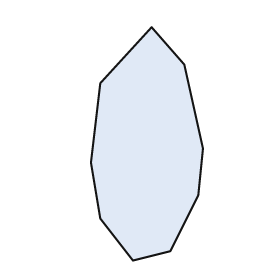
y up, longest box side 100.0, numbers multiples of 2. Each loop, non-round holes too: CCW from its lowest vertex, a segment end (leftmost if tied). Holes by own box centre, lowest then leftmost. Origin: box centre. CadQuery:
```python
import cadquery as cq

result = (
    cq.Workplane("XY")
    .moveTo(-6.0, -50.0)
    .lineTo(10.0, -46.0)
    .lineTo(22.0, -22.0)
    .lineTo(24.0, -2.0)
    .lineTo(16.0, 34.0)
    .lineTo(2.0, 50.0)
    .lineTo(-20.0, 26.0)
    .lineTo(-24.0, -8.0)
    .lineTo(-20.0, -32.0)
    .close()
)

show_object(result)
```